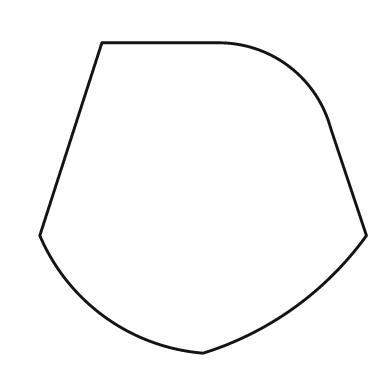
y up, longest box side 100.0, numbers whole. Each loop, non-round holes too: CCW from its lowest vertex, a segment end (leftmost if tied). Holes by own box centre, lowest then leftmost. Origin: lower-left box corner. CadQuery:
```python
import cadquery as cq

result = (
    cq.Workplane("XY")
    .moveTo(50.0, 0.0)
    .threePointArc((78.0, 14.0), (100.0, 36.0))
    .lineTo(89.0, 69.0)
    .threePointArc((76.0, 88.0), (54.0, 95.0))
    .lineTo(19.0, 95.0)
    .lineTo(0.0, 36.0)
    .threePointArc((20.0, 11.0), (50.0, 0.0))
    .close()
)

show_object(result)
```